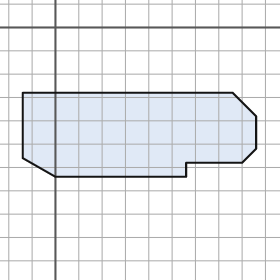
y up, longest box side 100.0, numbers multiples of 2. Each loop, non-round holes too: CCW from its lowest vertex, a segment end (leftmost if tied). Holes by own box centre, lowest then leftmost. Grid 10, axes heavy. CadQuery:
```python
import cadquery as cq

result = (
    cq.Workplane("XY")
    .moveTo(0.0, -64.0)
    .lineTo(56.0, -64.0)
    .lineTo(56.0, -58.0)
    .lineTo(80.0, -58.0)
    .lineTo(86.0, -52.0)
    .lineTo(86.0, -38.0)
    .lineTo(76.0, -28.0)
    .lineTo(-14.0, -28.0)
    .lineTo(-14.0, -56.0)
    .close()
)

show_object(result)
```